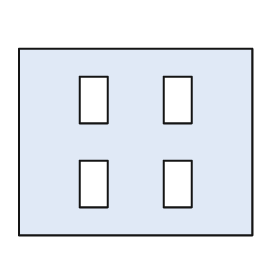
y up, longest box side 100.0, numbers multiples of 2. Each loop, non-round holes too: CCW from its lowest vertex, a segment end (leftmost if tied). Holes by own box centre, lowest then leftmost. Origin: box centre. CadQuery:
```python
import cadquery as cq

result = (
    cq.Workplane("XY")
    .moveTo(-50.0, -40.0)
    .lineTo(50.0, -40.0)
    .lineTo(50.0, 40.0)
    .lineTo(-50.0, 40.0)
    .close()
    .moveTo(-24.0, -28.0)
    .lineTo(-12.0, -28.0)
    .lineTo(-12.0, -8.0)
    .lineTo(-24.0, -8.0)
    .close()
    .moveTo(12.0, -28.0)
    .lineTo(24.0, -28.0)
    .lineTo(24.0, -8.0)
    .lineTo(12.0, -8.0)
    .close()
    .moveTo(-24.0, 8.0)
    .lineTo(-12.0, 8.0)
    .lineTo(-12.0, 28.0)
    .lineTo(-24.0, 28.0)
    .close()
    .moveTo(12.0, 8.0)
    .lineTo(24.0, 8.0)
    .lineTo(24.0, 28.0)
    .lineTo(12.0, 28.0)
    .close()
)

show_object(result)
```